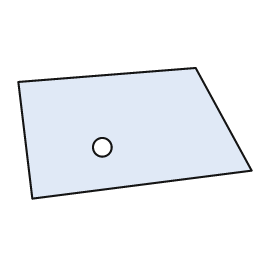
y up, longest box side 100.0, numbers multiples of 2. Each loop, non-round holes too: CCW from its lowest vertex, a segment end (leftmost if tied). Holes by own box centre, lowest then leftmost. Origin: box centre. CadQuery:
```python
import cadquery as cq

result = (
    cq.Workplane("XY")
    .moveTo(-44.0, -28.0)
    .lineTo(50.0, -16.0)
    .lineTo(26.0, 28.0)
    .lineTo(-50.0, 22.0)
    .close()
    .moveTo(-14.0, -6.0)
    .circle(4.0)
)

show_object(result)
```